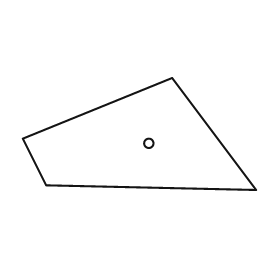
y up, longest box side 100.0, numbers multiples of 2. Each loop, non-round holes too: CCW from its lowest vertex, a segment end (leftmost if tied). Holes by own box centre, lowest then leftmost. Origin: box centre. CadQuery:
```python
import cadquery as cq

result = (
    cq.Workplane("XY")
    .moveTo(50.0, -24.0)
    .lineTo(14.0, 24.0)
    .lineTo(-50.0, -2.0)
    .lineTo(-40.0, -22.0)
    .close()
    .moveTo(4.0, -4.0)
    .circle(2.0)
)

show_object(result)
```